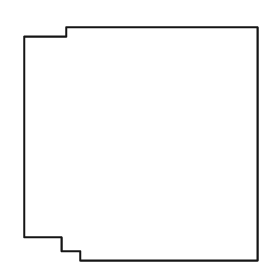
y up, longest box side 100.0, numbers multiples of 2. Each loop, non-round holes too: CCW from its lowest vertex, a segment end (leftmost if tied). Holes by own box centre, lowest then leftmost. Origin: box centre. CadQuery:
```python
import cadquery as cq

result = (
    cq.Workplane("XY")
    .moveTo(-26.0, -50.0)
    .lineTo(50.0, -50.0)
    .lineTo(50.0, 50.0)
    .lineTo(-32.0, 50.0)
    .lineTo(-32.0, 46.0)
    .lineTo(-50.0, 46.0)
    .lineTo(-50.0, -40.0)
    .lineTo(-34.0, -40.0)
    .lineTo(-34.0, -46.0)
    .lineTo(-26.0, -46.0)
    .close()
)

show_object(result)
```